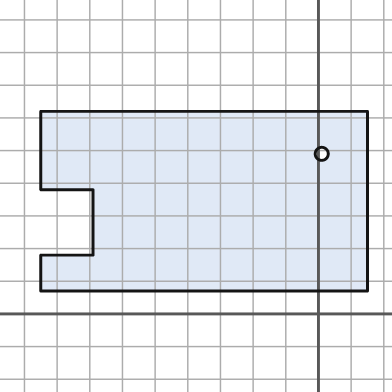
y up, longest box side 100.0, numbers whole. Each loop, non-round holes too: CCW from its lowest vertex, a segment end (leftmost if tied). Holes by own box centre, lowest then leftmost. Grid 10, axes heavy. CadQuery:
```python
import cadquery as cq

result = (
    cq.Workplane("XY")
    .moveTo(-85.0, 7.0)
    .lineTo(15.0, 7.0)
    .lineTo(15.0, 62.0)
    .lineTo(-85.0, 62.0)
    .lineTo(-85.0, 38.0)
    .lineTo(-69.0, 38.0)
    .lineTo(-69.0, 18.0)
    .lineTo(-85.0, 18.0)
    .close()
    .moveTo(1.0, 49.0)
    .circle(2.0)
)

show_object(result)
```